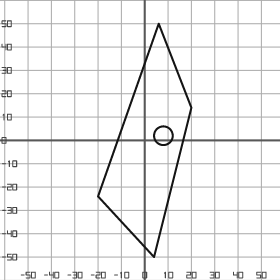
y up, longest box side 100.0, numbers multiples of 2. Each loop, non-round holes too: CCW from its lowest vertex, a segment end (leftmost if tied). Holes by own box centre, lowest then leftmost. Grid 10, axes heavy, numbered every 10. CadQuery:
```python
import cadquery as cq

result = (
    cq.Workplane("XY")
    .moveTo(4.0, -50.0)
    .lineTo(20.0, 14.0)
    .lineTo(6.0, 50.0)
    .lineTo(-20.0, -24.0)
    .close()
    .moveTo(8.0, 2.0)
    .circle(4.0)
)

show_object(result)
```